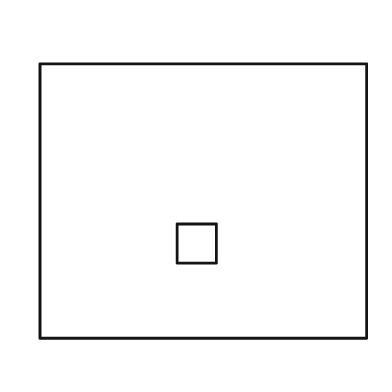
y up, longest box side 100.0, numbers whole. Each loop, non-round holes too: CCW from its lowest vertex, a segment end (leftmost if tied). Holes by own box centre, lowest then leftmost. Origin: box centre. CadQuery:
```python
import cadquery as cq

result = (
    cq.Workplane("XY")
    .moveTo(-50.0, -42.0)
    .lineTo(50.0, -42.0)
    .lineTo(50.0, 42.0)
    .lineTo(-50.0, 42.0)
    .close()
    .moveTo(-8.0, -19.0)
    .lineTo(4.0, -19.0)
    .lineTo(4.0, -7.0)
    .lineTo(-8.0, -7.0)
    .close()
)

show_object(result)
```